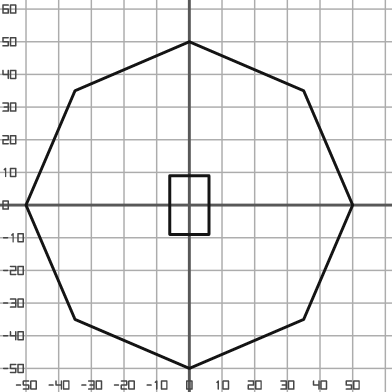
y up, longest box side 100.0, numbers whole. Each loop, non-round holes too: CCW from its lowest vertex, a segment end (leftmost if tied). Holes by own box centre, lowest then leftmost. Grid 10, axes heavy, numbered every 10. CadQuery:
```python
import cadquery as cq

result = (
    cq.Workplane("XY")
    .moveTo(0.0, -50.0)
    .lineTo(35.0, -35.0)
    .lineTo(50.0, 0.0)
    .lineTo(35.0, 35.0)
    .lineTo(0.0, 50.0)
    .lineTo(-35.0, 35.0)
    .lineTo(-50.0, 0.0)
    .lineTo(-35.0, -35.0)
    .close()
    .moveTo(-6.0, -9.0)
    .lineTo(6.0, -9.0)
    .lineTo(6.0, 9.0)
    .lineTo(-6.0, 9.0)
    .close()
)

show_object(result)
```